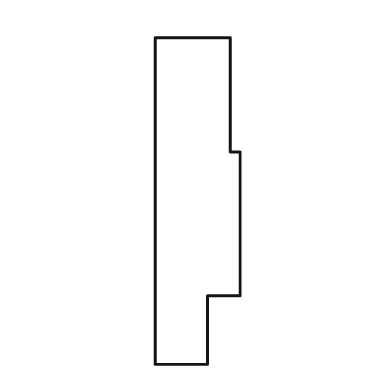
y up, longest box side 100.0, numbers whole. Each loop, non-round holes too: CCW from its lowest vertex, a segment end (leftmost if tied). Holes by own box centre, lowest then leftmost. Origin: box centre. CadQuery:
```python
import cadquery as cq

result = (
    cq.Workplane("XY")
    .moveTo(-13.0, -50.0)
    .lineTo(3.0, -50.0)
    .lineTo(3.0, -29.0)
    .lineTo(13.0, -29.0)
    .lineTo(13.0, 15.0)
    .lineTo(10.0, 15.0)
    .lineTo(10.0, 50.0)
    .lineTo(-13.0, 50.0)
    .close()
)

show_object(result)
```